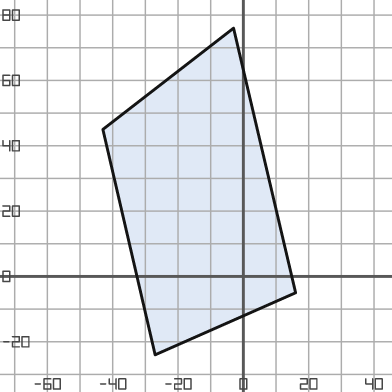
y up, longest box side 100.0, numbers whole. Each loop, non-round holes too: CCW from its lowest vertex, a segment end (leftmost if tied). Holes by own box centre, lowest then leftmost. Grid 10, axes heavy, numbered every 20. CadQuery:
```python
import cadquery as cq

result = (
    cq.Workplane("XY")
    .moveTo(-27.0, -24.0)
    .lineTo(16.0, -5.0)
    .lineTo(-3.0, 76.0)
    .lineTo(-43.0, 45.0)
    .close()
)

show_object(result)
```